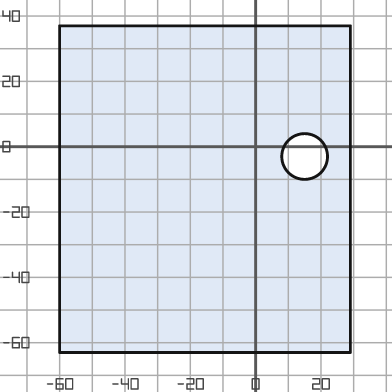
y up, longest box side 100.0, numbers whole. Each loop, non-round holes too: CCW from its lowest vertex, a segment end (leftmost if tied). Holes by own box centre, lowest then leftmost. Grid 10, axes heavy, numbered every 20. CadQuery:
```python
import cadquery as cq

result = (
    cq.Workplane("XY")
    .moveTo(-60.0, -63.0)
    .lineTo(29.0, -63.0)
    .lineTo(29.0, 37.0)
    .lineTo(-60.0, 37.0)
    .close()
    .moveTo(15.0, -3.0)
    .circle(7.0)
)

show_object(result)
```